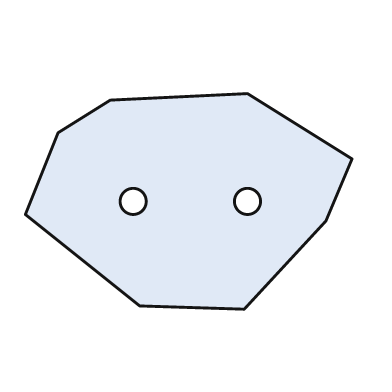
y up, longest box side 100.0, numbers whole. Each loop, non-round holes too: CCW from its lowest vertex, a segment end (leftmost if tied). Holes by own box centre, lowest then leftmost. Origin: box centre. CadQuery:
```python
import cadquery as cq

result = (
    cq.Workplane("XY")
    .moveTo(17.0, -33.0)
    .lineTo(42.0, -6.0)
    .lineTo(50.0, 13.0)
    .lineTo(18.0, 33.0)
    .lineTo(-24.0, 31.0)
    .lineTo(-40.0, 21.0)
    .lineTo(-50.0, -4.0)
    .lineTo(-15.0, -32.0)
    .close()
    .moveTo(-17.0, 0.0)
    .circle(4.0)
    .moveTo(18.0, 0.0)
    .circle(4.0)
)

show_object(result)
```